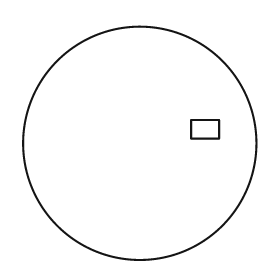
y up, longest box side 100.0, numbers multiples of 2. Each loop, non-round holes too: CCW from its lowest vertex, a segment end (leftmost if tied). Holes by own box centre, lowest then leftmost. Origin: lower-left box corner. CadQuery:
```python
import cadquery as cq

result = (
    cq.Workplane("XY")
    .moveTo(50.0, 50.0)
    .circle(50.0)
    .moveTo(72.0, 52.0)
    .lineTo(84.0, 52.0)
    .lineTo(84.0, 60.0)
    .lineTo(72.0, 60.0)
    .close()
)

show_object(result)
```